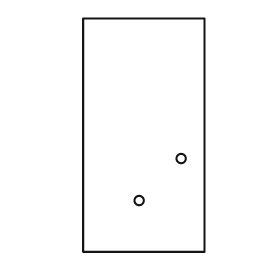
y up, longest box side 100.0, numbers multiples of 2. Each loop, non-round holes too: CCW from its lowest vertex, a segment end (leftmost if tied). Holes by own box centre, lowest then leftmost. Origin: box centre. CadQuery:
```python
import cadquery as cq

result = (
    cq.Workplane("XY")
    .moveTo(-26.0, -50.0)
    .lineTo(26.0, -50.0)
    .lineTo(26.0, 50.0)
    .lineTo(-26.0, 50.0)
    .close()
    .moveTo(-2.0, -28.0)
    .circle(2.0)
    .moveTo(16.0, -10.0)
    .circle(2.0)
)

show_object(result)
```